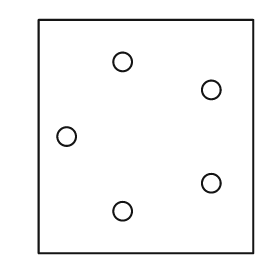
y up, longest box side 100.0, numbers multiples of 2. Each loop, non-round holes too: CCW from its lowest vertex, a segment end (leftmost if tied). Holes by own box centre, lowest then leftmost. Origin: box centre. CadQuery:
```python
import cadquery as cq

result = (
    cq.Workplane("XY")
    .moveTo(-46.0, -50.0)
    .lineTo(46.0, -50.0)
    .lineTo(46.0, 50.0)
    .lineTo(-46.0, 50.0)
    .close()
    .moveTo(-10.0, -32.0)
    .circle(4.0)
    .moveTo(28.0, -20.0)
    .circle(4.0)
    .moveTo(-34.0, 0.0)
    .circle(4.0)
    .moveTo(28.0, 20.0)
    .circle(4.0)
    .moveTo(-10.0, 32.0)
    .circle(4.0)
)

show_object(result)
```